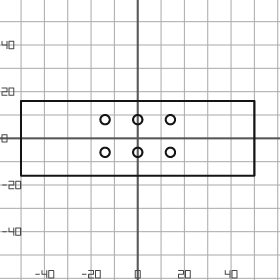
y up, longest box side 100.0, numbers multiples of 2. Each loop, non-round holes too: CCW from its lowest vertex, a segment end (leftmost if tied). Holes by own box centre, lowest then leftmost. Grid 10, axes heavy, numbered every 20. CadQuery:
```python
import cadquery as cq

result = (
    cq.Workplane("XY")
    .moveTo(-50.0, -16.0)
    .lineTo(50.0, -16.0)
    .lineTo(50.0, 16.0)
    .lineTo(-50.0, 16.0)
    .close()
    .moveTo(-14.0, -6.0)
    .circle(2.0)
    .moveTo(0.0, -6.0)
    .circle(2.0)
    .moveTo(14.0, -6.0)
    .circle(2.0)
    .moveTo(-14.0, 8.0)
    .circle(2.0)
    .moveTo(0.0, 8.0)
    .circle(2.0)
    .moveTo(14.0, 8.0)
    .circle(2.0)
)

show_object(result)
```